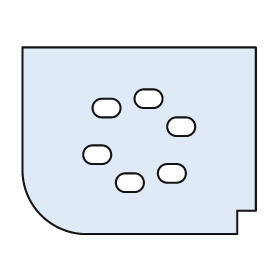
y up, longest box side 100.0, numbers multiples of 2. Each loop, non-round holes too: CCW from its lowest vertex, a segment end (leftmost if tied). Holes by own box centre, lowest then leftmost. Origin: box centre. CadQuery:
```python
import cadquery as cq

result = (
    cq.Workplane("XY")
    .moveTo(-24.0, -40.0)
    .lineTo(42.0, -40.0)
    .lineTo(42.0, -30.0)
    .lineTo(50.0, -30.0)
    .lineTo(50.0, 40.0)
    .lineTo(-50.0, 40.0)
    .lineTo(-50.0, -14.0)
    .threePointArc((-42.0, -32.0), (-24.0, -40.0))
    .close()
    .moveTo(-6.0, -22.0)
    .lineTo(-2.0, -22.0)
    .threePointArc((2.0, -18.0), (-2.0, -14.0))
    .lineTo(-6.0, -14.0)
    .threePointArc((-10.0, -18.0), (-6.0, -22.0))
    .close()
    .moveTo(12.0, -18.0)
    .lineTo(16.0, -18.0)
    .threePointArc((20.0, -14.0), (16.0, -10.0))
    .lineTo(12.0, -10.0)
    .threePointArc((8.0, -14.0), (12.0, -18.0))
    .close()
    .moveTo(-20.0, -10.0)
    .lineTo(-16.0, -10.0)
    .threePointArc((-12.0, -6.0), (-16.0, -2.0))
    .lineTo(-20.0, -2.0)
    .threePointArc((-24.0, -6.0), (-20.0, -10.0))
    .close()
    .moveTo(16.0, 2.0)
    .lineTo(20.0, 2.0)
    .threePointArc((24.0, 6.0), (20.0, 10.0))
    .lineTo(16.0, 10.0)
    .threePointArc((12.0, 6.0), (16.0, 2.0))
    .close()
    .moveTo(-16.0, 10.0)
    .lineTo(-12.0, 10.0)
    .threePointArc((-8.0, 14.0), (-12.0, 18.0))
    .lineTo(-16.0, 18.0)
    .threePointArc((-20.0, 14.0), (-16.0, 10.0))
    .close()
    .moveTo(2.0, 14.0)
    .lineTo(6.0, 14.0)
    .threePointArc((10.0, 18.0), (6.0, 22.0))
    .lineTo(2.0, 22.0)
    .threePointArc((-2.0, 18.0), (2.0, 14.0))
    .close()
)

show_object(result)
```